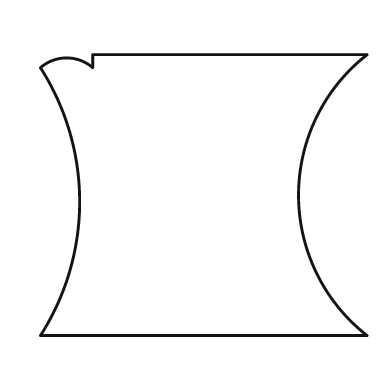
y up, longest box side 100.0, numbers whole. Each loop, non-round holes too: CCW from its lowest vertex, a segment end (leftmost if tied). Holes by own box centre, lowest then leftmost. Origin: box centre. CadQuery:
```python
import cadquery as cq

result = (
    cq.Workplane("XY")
    .moveTo(-50.0, -43.0)
    .lineTo(50.0, -43.0)
    .threePointArc((29.0, 0.0), (50.0, 43.0))
    .lineTo(-34.0, 43.0)
    .lineTo(-34.0, 39.0)
    .threePointArc((-42.0, 42.0), (-50.0, 39.0))
    .threePointArc((-38.0, -2.0), (-50.0, -43.0))
    .close()
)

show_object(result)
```